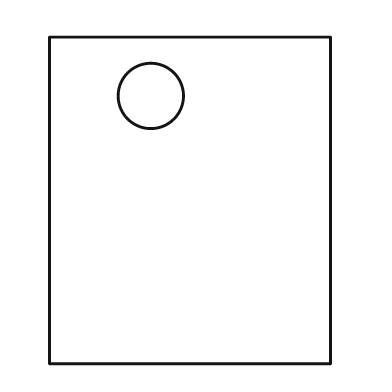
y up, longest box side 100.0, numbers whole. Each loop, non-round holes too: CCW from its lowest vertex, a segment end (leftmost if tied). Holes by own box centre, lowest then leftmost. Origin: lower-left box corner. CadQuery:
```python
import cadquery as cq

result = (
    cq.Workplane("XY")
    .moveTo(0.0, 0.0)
    .lineTo(86.0, 0.0)
    .lineTo(86.0, 100.0)
    .lineTo(0.0, 100.0)
    .close()
    .moveTo(31.0, 82.0)
    .circle(10.0)
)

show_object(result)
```